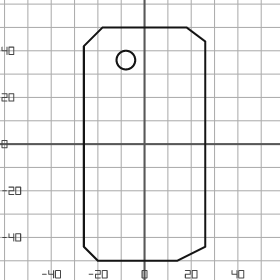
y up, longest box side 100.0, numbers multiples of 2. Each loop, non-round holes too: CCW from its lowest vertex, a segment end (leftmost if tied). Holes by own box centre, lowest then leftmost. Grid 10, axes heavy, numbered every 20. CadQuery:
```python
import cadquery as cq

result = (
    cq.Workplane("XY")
    .moveTo(-20.0, -50.0)
    .lineTo(14.0, -50.0)
    .lineTo(26.0, -44.0)
    .lineTo(26.0, 44.0)
    .lineTo(18.0, 50.0)
    .lineTo(-18.0, 50.0)
    .lineTo(-26.0, 42.0)
    .lineTo(-26.0, -44.0)
    .close()
    .moveTo(-8.0, 36.0)
    .circle(4.0)
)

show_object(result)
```